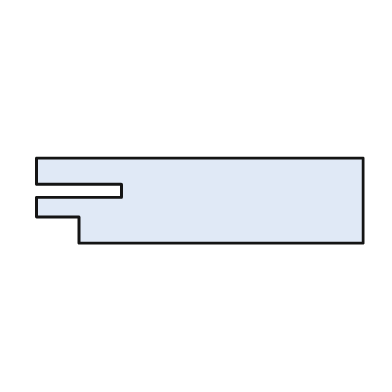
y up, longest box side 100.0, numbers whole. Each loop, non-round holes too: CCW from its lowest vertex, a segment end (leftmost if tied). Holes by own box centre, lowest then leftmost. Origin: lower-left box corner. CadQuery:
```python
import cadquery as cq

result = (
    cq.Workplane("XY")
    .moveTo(13.0, 0.0)
    .lineTo(100.0, 0.0)
    .lineTo(100.0, 26.0)
    .lineTo(0.0, 26.0)
    .lineTo(0.0, 18.0)
    .lineTo(26.0, 18.0)
    .lineTo(26.0, 14.0)
    .lineTo(0.0, 14.0)
    .lineTo(0.0, 8.0)
    .lineTo(13.0, 8.0)
    .close()
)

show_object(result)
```